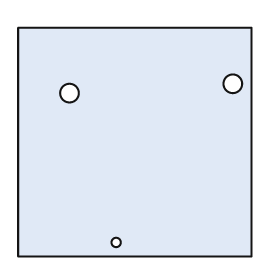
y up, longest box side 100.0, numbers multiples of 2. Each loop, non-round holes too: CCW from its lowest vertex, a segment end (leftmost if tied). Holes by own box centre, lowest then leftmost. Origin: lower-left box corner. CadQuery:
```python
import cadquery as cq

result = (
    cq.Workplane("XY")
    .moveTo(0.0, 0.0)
    .lineTo(100.0, 0.0)
    .lineTo(100.0, 98.0)
    .lineTo(0.0, 98.0)
    .close()
    .moveTo(42.0, 6.0)
    .circle(2.0)
    .moveTo(22.0, 70.0)
    .circle(4.0)
    .moveTo(92.0, 74.0)
    .circle(4.0)
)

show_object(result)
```